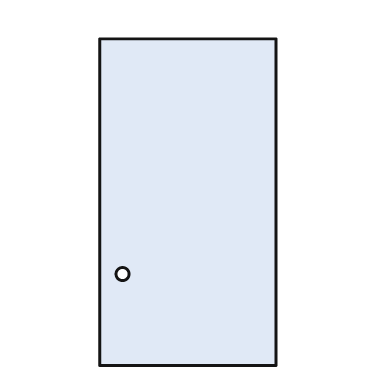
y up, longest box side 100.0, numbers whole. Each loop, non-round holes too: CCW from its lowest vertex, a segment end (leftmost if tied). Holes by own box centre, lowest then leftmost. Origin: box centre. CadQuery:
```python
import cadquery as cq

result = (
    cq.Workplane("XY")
    .moveTo(-27.0, -50.0)
    .lineTo(27.0, -50.0)
    .lineTo(27.0, 50.0)
    .lineTo(-27.0, 50.0)
    .close()
    .moveTo(-20.0, -22.0)
    .circle(2.0)
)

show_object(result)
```